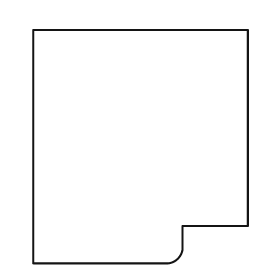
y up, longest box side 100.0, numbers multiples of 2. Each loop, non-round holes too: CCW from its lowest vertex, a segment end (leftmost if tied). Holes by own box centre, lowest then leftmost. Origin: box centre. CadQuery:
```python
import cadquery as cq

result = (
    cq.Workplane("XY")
    .moveTo(-46.0, -50.0)
    .lineTo(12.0, -50.0)
    .threePointArc((16.0, -48.0), (18.0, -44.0))
    .lineTo(18.0, -34.0)
    .lineTo(46.0, -34.0)
    .lineTo(46.0, 50.0)
    .lineTo(-46.0, 50.0)
    .close()
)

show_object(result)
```